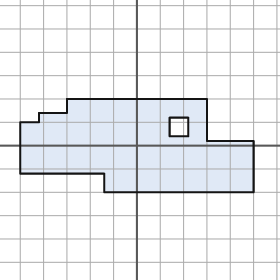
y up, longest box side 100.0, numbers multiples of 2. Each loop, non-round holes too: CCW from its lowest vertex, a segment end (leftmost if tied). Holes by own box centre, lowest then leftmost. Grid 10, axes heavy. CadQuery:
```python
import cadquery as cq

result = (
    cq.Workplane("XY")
    .moveTo(-14.0, -20.0)
    .lineTo(50.0, -20.0)
    .lineTo(50.0, 2.0)
    .lineTo(30.0, 2.0)
    .lineTo(30.0, 20.0)
    .lineTo(-30.0, 20.0)
    .lineTo(-30.0, 14.0)
    .lineTo(-42.0, 14.0)
    .lineTo(-42.0, 10.0)
    .lineTo(-50.0, 10.0)
    .lineTo(-50.0, -12.0)
    .lineTo(-14.0, -12.0)
    .close()
    .moveTo(14.0, 4.0)
    .lineTo(22.0, 4.0)
    .lineTo(22.0, 12.0)
    .lineTo(14.0, 12.0)
    .close()
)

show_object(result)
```